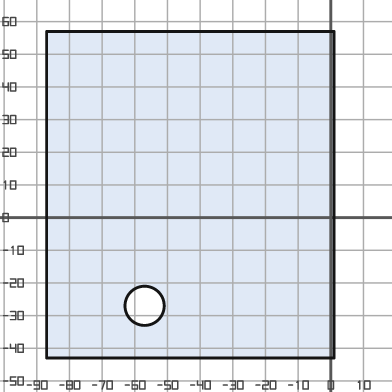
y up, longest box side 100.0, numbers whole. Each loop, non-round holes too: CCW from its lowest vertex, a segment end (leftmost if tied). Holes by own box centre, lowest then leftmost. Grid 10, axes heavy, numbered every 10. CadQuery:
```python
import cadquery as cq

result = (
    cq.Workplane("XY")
    .moveTo(-87.0, -43.0)
    .lineTo(1.0, -43.0)
    .lineTo(1.0, 57.0)
    .lineTo(-87.0, 57.0)
    .close()
    .moveTo(-57.0, -27.0)
    .circle(6.0)
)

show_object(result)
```